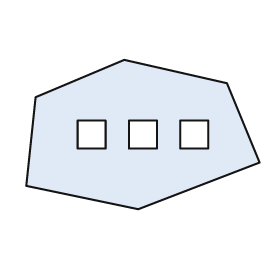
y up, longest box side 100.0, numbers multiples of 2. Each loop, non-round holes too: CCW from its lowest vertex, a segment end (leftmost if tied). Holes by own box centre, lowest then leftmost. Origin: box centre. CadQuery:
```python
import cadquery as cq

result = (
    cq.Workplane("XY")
    .moveTo(-2.0, -32.0)
    .lineTo(50.0, -12.0)
    .lineTo(36.0, 22.0)
    .lineTo(-8.0, 32.0)
    .lineTo(-46.0, 16.0)
    .lineTo(-50.0, -22.0)
    .close()
    .moveTo(-28.0, -6.0)
    .lineTo(-16.0, -6.0)
    .lineTo(-16.0, 6.0)
    .lineTo(-28.0, 6.0)
    .close()
    .moveTo(-6.0, -6.0)
    .lineTo(6.0, -6.0)
    .lineTo(6.0, 6.0)
    .lineTo(-6.0, 6.0)
    .close()
    .moveTo(16.0, -6.0)
    .lineTo(28.0, -6.0)
    .lineTo(28.0, 6.0)
    .lineTo(16.0, 6.0)
    .close()
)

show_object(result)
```